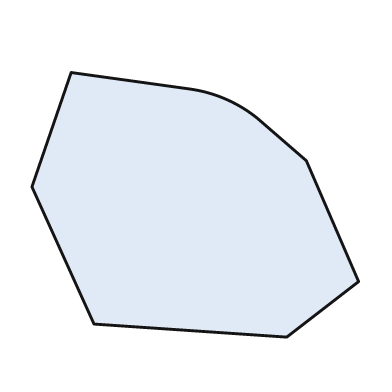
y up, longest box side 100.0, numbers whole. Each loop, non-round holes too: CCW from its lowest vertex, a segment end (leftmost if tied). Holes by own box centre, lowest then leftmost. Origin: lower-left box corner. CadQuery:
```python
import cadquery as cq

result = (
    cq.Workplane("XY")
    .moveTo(78.0, 0.0)
    .lineTo(100.0, 17.0)
    .lineTo(84.0, 54.0)
    .lineTo(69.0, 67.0)
    .threePointArc((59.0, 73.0), (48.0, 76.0))
    .lineTo(12.0, 81.0)
    .lineTo(0.0, 46.0)
    .lineTo(19.0, 4.0)
    .close()
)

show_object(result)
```